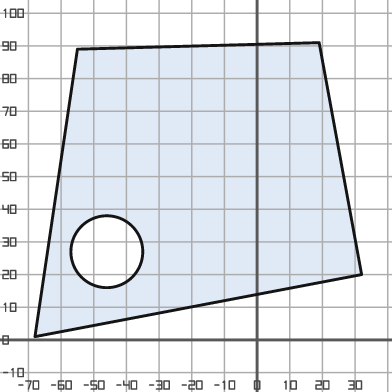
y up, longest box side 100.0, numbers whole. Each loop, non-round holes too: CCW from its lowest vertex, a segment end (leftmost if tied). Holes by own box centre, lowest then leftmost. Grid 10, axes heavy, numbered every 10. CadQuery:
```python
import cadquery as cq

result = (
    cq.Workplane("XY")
    .moveTo(-68.0, 1.0)
    .lineTo(32.0, 20.0)
    .lineTo(19.0, 91.0)
    .lineTo(-55.0, 89.0)
    .close()
    .moveTo(-46.0, 27.0)
    .circle(11.0)
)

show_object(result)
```